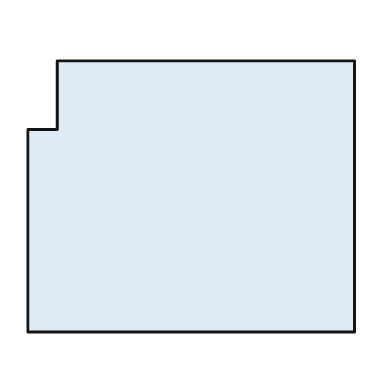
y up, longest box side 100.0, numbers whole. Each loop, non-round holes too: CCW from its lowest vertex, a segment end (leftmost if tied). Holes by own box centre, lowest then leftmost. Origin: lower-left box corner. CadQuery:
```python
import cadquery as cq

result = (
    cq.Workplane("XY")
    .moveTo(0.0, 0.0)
    .lineTo(100.0, 0.0)
    .lineTo(100.0, 83.0)
    .lineTo(9.0, 83.0)
    .lineTo(9.0, 62.0)
    .lineTo(0.0, 62.0)
    .close()
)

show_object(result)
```